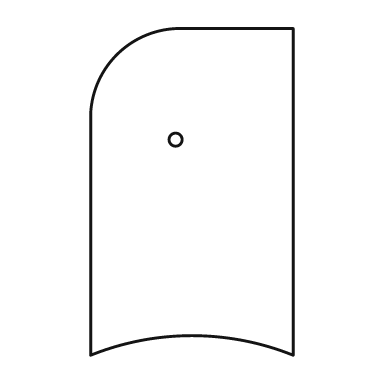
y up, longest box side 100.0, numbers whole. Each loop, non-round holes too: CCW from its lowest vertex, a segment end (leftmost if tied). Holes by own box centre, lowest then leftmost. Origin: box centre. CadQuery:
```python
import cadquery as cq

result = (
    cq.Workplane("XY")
    .moveTo(-31.0, -50.0)
    .threePointArc((0.0, -44.0), (31.0, -50.0))
    .lineTo(31.0, 50.0)
    .lineTo(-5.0, 50.0)
    .threePointArc((-23.0, 42.0), (-31.0, 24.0))
    .close()
    .moveTo(-5.0, 16.0)
    .circle(2.0)
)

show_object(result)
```